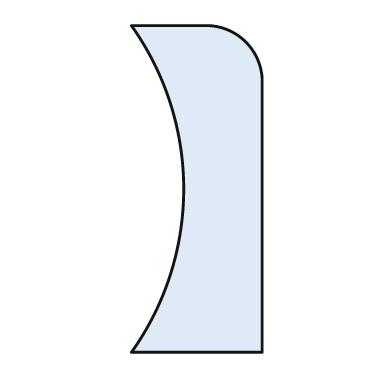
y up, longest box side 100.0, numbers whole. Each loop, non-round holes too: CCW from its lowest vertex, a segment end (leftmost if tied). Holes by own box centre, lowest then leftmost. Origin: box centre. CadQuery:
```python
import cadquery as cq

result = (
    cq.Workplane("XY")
    .moveTo(-20.0, -50.0)
    .lineTo(20.0, -50.0)
    .lineTo(20.0, 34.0)
    .threePointArc((15.0, 45.0), (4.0, 50.0))
    .lineTo(-20.0, 50.0)
    .threePointArc((-4.0, 0.0), (-20.0, -50.0))
    .close()
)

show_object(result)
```